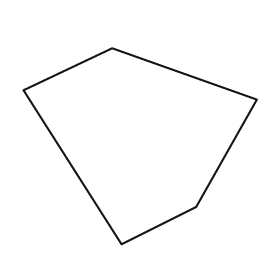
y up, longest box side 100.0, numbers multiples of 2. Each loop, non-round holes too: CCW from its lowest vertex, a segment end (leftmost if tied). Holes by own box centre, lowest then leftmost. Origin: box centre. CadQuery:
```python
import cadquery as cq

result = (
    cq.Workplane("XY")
    .moveTo(-8.0, -42.0)
    .lineTo(24.0, -26.0)
    .lineTo(50.0, 20.0)
    .lineTo(-12.0, 42.0)
    .lineTo(-50.0, 24.0)
    .close()
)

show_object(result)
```